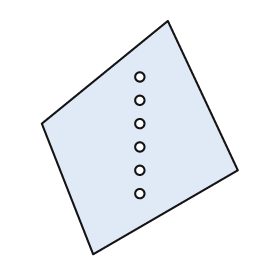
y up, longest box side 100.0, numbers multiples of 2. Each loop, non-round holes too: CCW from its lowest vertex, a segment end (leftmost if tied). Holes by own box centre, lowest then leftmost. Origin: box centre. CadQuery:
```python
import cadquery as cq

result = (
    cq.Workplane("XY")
    .moveTo(-20.0, -50.0)
    .lineTo(42.0, -14.0)
    .lineTo(12.0, 50.0)
    .lineTo(-42.0, 6.0)
    .close()
    .moveTo(0.0, -24.0)
    .circle(2.0)
    .moveTo(0.0, -14.0)
    .circle(2.0)
    .moveTo(0.0, -4.0)
    .circle(2.0)
    .moveTo(0.0, 6.0)
    .circle(2.0)
    .moveTo(0.0, 16.0)
    .circle(2.0)
    .moveTo(0.0, 26.0)
    .circle(2.0)
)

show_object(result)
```